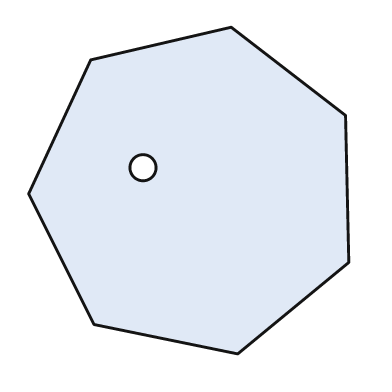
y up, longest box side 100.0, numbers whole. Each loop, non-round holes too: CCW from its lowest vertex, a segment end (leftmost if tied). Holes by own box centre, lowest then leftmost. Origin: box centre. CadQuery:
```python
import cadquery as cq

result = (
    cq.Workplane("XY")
    .moveTo(15.0, -50.0)
    .lineTo(49.0, -22.0)
    .lineTo(48.0, 23.0)
    .lineTo(13.0, 50.0)
    .lineTo(-30.0, 40.0)
    .lineTo(-49.0, -1.0)
    .lineTo(-29.0, -41.0)
    .close()
    .moveTo(-14.0, 7.0)
    .circle(4.0)
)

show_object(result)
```